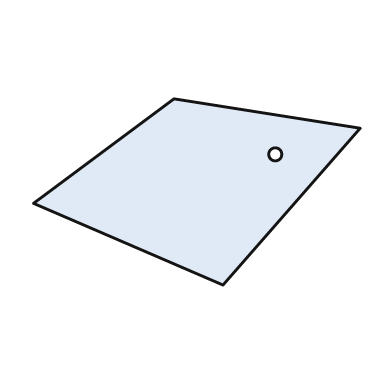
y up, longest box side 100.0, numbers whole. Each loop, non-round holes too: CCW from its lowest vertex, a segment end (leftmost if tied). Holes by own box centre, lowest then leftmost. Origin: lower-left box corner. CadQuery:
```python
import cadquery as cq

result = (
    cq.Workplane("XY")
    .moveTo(58.0, 0.0)
    .lineTo(100.0, 48.0)
    .lineTo(43.0, 57.0)
    .lineTo(0.0, 25.0)
    .close()
    .moveTo(74.0, 40.0)
    .circle(2.0)
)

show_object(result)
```